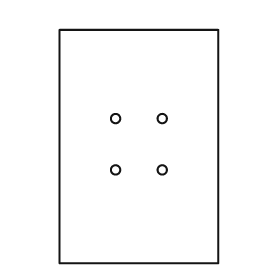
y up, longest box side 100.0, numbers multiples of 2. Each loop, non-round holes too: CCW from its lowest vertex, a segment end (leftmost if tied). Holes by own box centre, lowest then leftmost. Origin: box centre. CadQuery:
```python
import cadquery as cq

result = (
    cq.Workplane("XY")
    .moveTo(-34.0, -50.0)
    .lineTo(34.0, -50.0)
    .lineTo(34.0, 50.0)
    .lineTo(-34.0, 50.0)
    .close()
    .moveTo(-10.0, -10.0)
    .circle(2.0)
    .moveTo(10.0, -10.0)
    .circle(2.0)
    .moveTo(-10.0, 12.0)
    .circle(2.0)
    .moveTo(10.0, 12.0)
    .circle(2.0)
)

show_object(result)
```